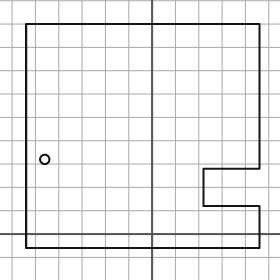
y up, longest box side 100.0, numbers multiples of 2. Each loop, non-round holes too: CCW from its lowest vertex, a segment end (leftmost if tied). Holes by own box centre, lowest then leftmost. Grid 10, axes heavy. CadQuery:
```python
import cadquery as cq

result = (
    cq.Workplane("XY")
    .moveTo(-54.0, -6.0)
    .lineTo(46.0, -6.0)
    .lineTo(46.0, 12.0)
    .lineTo(22.0, 12.0)
    .lineTo(22.0, 28.0)
    .lineTo(46.0, 28.0)
    .lineTo(46.0, 90.0)
    .lineTo(-54.0, 90.0)
    .close()
    .moveTo(-46.0, 32.0)
    .circle(2.0)
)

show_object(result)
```